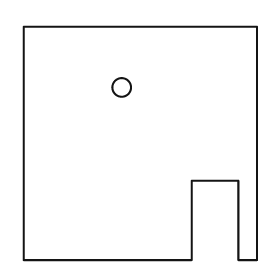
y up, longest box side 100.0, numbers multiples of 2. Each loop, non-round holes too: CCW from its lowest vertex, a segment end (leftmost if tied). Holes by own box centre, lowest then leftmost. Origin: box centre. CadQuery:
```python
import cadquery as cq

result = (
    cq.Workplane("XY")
    .moveTo(-50.0, -50.0)
    .lineTo(22.0, -50.0)
    .lineTo(22.0, -16.0)
    .lineTo(42.0, -16.0)
    .lineTo(42.0, -50.0)
    .lineTo(50.0, -50.0)
    .lineTo(50.0, 50.0)
    .lineTo(-50.0, 50.0)
    .close()
    .moveTo(-8.0, 24.0)
    .circle(4.0)
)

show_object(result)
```